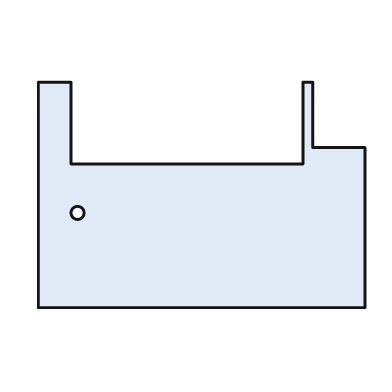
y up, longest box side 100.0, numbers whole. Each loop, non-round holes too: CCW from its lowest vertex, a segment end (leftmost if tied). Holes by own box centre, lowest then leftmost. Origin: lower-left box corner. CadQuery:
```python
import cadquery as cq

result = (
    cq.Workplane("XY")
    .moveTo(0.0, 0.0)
    .lineTo(100.0, 0.0)
    .lineTo(100.0, 49.0)
    .lineTo(84.0, 49.0)
    .lineTo(84.0, 69.0)
    .lineTo(81.0, 69.0)
    .lineTo(81.0, 44.0)
    .lineTo(10.0, 44.0)
    .lineTo(10.0, 69.0)
    .lineTo(0.0, 69.0)
    .close()
    .moveTo(12.0, 29.0)
    .circle(2.0)
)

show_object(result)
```